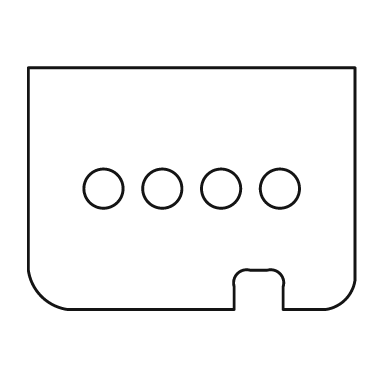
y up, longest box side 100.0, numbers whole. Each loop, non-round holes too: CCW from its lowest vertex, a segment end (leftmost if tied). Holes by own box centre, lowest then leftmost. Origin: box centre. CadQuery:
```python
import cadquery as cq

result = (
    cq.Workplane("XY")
    .moveTo(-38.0, -37.0)
    .lineTo(13.0, -37.0)
    .lineTo(13.0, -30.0)
    .threePointArc((14.0, -26.0), (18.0, -25.0))
    .lineTo(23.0, -25.0)
    .threePointArc((27.0, -26.0), (28.0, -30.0))
    .lineTo(28.0, -37.0)
    .lineTo(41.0, -37.0)
    .threePointArc((47.0, -34.0), (50.0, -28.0))
    .lineTo(50.0, 37.0)
    .lineTo(-50.0, 37.0)
    .lineTo(-50.0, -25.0)
    .threePointArc((-46.0, -33.0), (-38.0, -37.0))
    .close()
    .moveTo(-27.0, 0.0)
    .circle(6.0)
    .moveTo(-9.0, 0.0)
    .circle(6.0)
    .moveTo(9.0, 0.0)
    .circle(6.0)
    .moveTo(27.0, 0.0)
    .circle(6.0)
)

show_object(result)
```